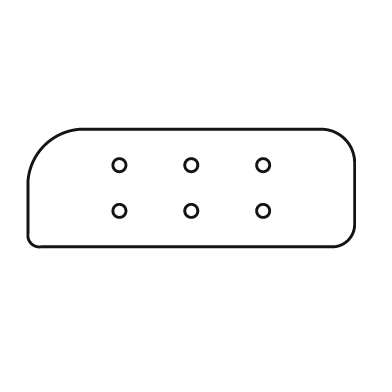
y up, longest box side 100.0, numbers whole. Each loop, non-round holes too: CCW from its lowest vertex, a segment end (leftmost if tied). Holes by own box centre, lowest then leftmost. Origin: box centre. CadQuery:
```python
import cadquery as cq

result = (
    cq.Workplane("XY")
    .moveTo(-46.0, -18.0)
    .lineTo(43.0, -18.0)
    .threePointArc((48.0, -16.0), (50.0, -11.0))
    .lineTo(50.0, 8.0)
    .threePointArc((47.0, 15.0), (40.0, 18.0))
    .lineTo(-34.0, 18.0)
    .threePointArc((-45.0, 13.0), (-50.0, 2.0))
    .lineTo(-50.0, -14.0)
    .threePointArc((-49.0, -17.0), (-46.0, -18.0))
    .close()
    .moveTo(-22.0, -7.0)
    .circle(2.0)
    .moveTo(0.0, -7.0)
    .circle(2.0)
    .moveTo(22.0, -7.0)
    .circle(2.0)
    .moveTo(-22.0, 7.0)
    .circle(2.0)
    .moveTo(0.0, 7.0)
    .circle(2.0)
    .moveTo(22.0, 7.0)
    .circle(2.0)
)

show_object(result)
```